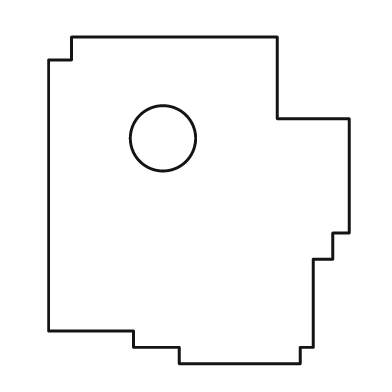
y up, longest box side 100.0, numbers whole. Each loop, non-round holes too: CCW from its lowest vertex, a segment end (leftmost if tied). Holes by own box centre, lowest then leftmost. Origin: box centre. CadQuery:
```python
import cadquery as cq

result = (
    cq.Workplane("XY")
    .moveTo(-6.0, -50.0)
    .lineTo(31.0, -50.0)
    .lineTo(31.0, -45.0)
    .lineTo(35.0, -45.0)
    .lineTo(35.0, -18.0)
    .lineTo(41.0, -18.0)
    .lineTo(41.0, -10.0)
    .lineTo(46.0, -10.0)
    .lineTo(46.0, 25.0)
    .lineTo(24.0, 25.0)
    .lineTo(24.0, 50.0)
    .lineTo(-39.0, 50.0)
    .lineTo(-39.0, 43.0)
    .lineTo(-46.0, 43.0)
    .lineTo(-46.0, -40.0)
    .lineTo(-20.0, -40.0)
    .lineTo(-20.0, -45.0)
    .lineTo(-6.0, -45.0)
    .close()
    .moveTo(-11.0, 19.0)
    .circle(10.0)
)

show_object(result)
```